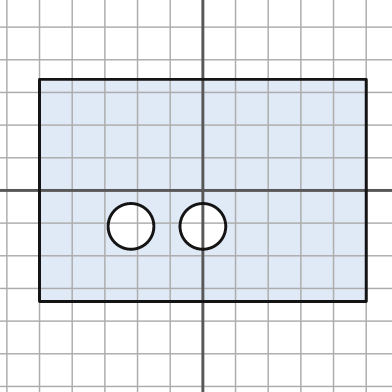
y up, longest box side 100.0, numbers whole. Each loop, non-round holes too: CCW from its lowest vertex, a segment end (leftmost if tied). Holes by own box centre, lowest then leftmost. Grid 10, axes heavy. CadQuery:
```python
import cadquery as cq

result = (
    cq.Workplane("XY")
    .moveTo(-50.0, -34.0)
    .lineTo(50.0, -34.0)
    .lineTo(50.0, 34.0)
    .lineTo(-50.0, 34.0)
    .close()
    .moveTo(-22.0, -11.0)
    .circle(7.0)
    .moveTo(0.0, -11.0)
    .circle(7.0)
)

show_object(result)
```